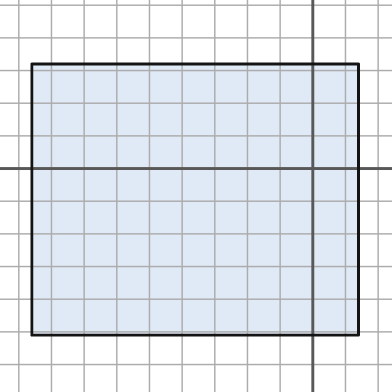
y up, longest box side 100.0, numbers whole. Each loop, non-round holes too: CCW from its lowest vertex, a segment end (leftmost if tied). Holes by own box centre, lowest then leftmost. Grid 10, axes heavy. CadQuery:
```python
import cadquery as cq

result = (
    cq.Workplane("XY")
    .moveTo(-86.0, -51.0)
    .lineTo(14.0, -51.0)
    .lineTo(14.0, 32.0)
    .lineTo(-86.0, 32.0)
    .close()
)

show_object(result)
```